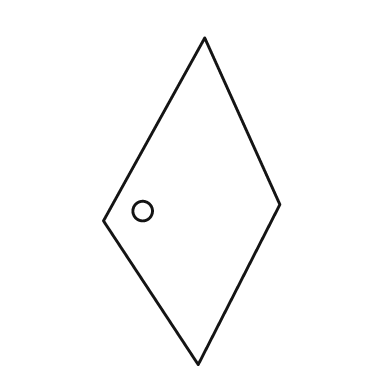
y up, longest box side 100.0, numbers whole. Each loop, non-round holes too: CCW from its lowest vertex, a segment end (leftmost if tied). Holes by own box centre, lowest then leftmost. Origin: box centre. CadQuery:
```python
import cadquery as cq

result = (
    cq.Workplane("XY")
    .moveTo(2.0, -50.0)
    .lineTo(27.0, -1.0)
    .lineTo(4.0, 50.0)
    .lineTo(-27.0, -6.0)
    .close()
    .moveTo(-15.0, -3.0)
    .circle(3.0)
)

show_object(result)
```